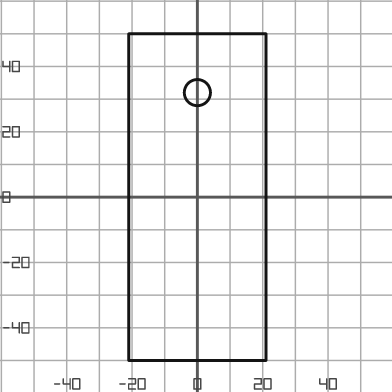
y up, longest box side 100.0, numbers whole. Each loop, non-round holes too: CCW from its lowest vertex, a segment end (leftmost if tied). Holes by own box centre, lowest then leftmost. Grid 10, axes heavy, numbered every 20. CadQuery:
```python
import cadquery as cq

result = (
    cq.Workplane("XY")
    .moveTo(-21.0, -50.0)
    .lineTo(21.0, -50.0)
    .lineTo(21.0, 50.0)
    .lineTo(-21.0, 50.0)
    .close()
    .moveTo(0.0, 32.0)
    .circle(4.0)
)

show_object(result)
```